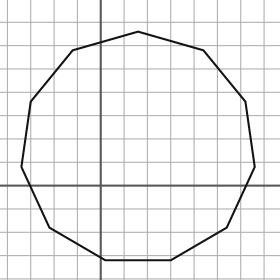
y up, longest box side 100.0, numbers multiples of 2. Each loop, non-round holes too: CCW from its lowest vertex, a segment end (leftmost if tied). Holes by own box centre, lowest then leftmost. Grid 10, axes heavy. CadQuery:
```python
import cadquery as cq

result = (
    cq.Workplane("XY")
    .moveTo(2.0, -32.0)
    .lineTo(30.0, -32.0)
    .lineTo(54.0, -18.0)
    .lineTo(66.0, 8.0)
    .lineTo(62.0, 36.0)
    .lineTo(44.0, 58.0)
    .lineTo(16.0, 66.0)
    .lineTo(-12.0, 58.0)
    .lineTo(-30.0, 36.0)
    .lineTo(-34.0, 8.0)
    .lineTo(-22.0, -18.0)
    .close()
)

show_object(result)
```